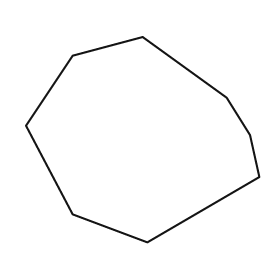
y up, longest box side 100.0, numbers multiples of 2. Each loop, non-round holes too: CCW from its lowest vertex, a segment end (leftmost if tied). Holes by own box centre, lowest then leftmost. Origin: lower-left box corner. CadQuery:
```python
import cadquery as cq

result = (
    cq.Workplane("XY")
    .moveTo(52.0, 0.0)
    .lineTo(100.0, 28.0)
    .lineTo(96.0, 46.0)
    .lineTo(86.0, 62.0)
    .lineTo(50.0, 88.0)
    .lineTo(20.0, 80.0)
    .lineTo(0.0, 50.0)
    .lineTo(20.0, 12.0)
    .close()
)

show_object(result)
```